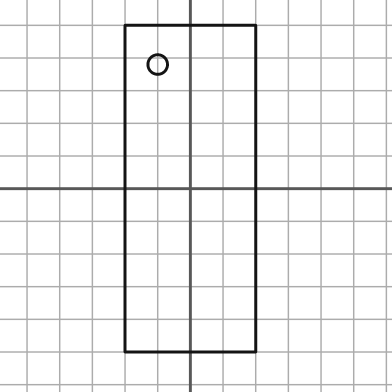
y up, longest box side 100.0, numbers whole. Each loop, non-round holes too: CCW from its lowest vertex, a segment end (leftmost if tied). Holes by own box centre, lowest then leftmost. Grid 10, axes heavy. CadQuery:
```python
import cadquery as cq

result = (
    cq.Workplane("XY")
    .moveTo(-20.0, -50.0)
    .lineTo(20.0, -50.0)
    .lineTo(20.0, 50.0)
    .lineTo(-20.0, 50.0)
    .close()
    .moveTo(-10.0, 38.0)
    .circle(3.0)
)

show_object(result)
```